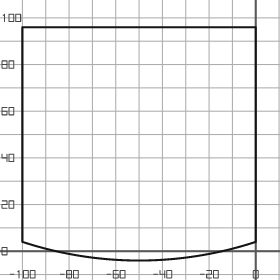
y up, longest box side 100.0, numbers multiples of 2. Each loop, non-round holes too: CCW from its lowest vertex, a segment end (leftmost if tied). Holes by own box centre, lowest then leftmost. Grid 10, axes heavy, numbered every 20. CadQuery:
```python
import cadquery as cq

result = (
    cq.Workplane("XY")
    .moveTo(-100.0, 4.0)
    .threePointArc((-50.0, -4.0), (0.0, 4.0))
    .lineTo(0.0, 96.0)
    .lineTo(-100.0, 96.0)
    .close()
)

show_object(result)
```